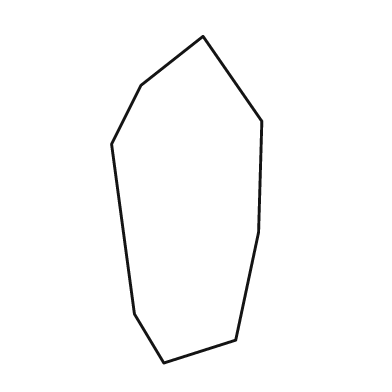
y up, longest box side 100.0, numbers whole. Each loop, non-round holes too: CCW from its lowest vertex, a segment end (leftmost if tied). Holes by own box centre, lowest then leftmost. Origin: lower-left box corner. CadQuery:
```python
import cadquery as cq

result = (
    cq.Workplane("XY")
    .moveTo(16.0, 0.0)
    .lineTo(38.0, 7.0)
    .lineTo(45.0, 40.0)
    .lineTo(46.0, 74.0)
    .lineTo(28.0, 100.0)
    .lineTo(9.0, 85.0)
    .lineTo(0.0, 67.0)
    .lineTo(7.0, 15.0)
    .close()
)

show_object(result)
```